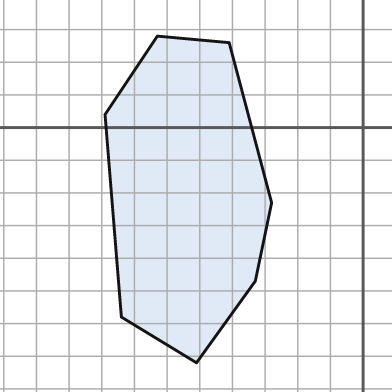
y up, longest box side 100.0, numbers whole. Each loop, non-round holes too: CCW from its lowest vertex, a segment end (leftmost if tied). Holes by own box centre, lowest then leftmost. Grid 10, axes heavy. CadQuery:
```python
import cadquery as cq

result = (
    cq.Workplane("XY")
    .moveTo(-51.0, -72.0)
    .lineTo(-33.0, -47.0)
    .lineTo(-28.0, -23.0)
    .lineTo(-41.0, 26.0)
    .lineTo(-63.0, 28.0)
    .lineTo(-79.0, 4.0)
    .lineTo(-74.0, -58.0)
    .close()
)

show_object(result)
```